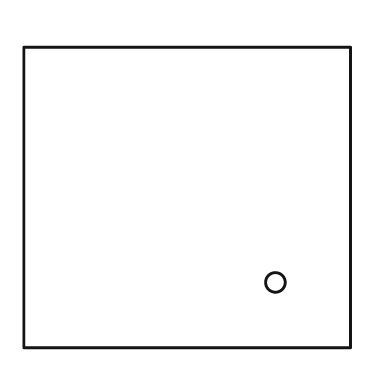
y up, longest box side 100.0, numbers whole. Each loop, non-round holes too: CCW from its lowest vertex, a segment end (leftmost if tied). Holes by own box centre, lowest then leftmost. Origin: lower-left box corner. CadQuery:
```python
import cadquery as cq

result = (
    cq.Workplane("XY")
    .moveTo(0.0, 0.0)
    .lineTo(100.0, 0.0)
    .lineTo(100.0, 92.0)
    .lineTo(0.0, 92.0)
    .close()
    .moveTo(77.0, 20.0)
    .circle(3.0)
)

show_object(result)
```